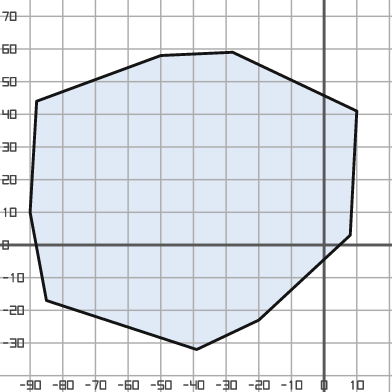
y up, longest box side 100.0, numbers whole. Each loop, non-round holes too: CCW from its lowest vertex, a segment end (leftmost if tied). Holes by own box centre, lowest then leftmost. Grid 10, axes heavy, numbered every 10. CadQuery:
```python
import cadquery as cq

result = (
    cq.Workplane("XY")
    .moveTo(-39.0, -32.0)
    .lineTo(-20.0, -23.0)
    .lineTo(8.0, 3.0)
    .lineTo(10.0, 41.0)
    .lineTo(-28.0, 59.0)
    .lineTo(-50.0, 58.0)
    .lineTo(-88.0, 44.0)
    .lineTo(-90.0, 10.0)
    .lineTo(-85.0, -17.0)
    .close()
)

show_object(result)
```